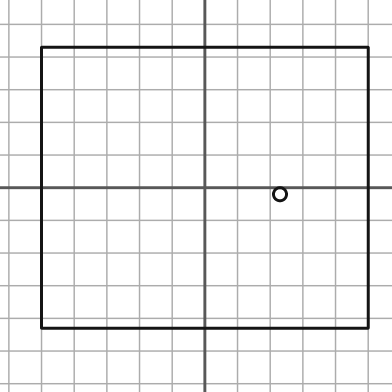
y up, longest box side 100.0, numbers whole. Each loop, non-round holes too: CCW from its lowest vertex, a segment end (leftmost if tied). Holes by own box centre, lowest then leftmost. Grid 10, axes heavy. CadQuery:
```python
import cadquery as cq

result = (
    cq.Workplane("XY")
    .moveTo(-50.0, -43.0)
    .lineTo(50.0, -43.0)
    .lineTo(50.0, 43.0)
    .lineTo(-50.0, 43.0)
    .close()
    .moveTo(23.0, -2.0)
    .circle(2.0)
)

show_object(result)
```